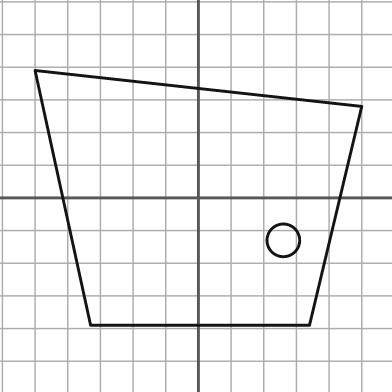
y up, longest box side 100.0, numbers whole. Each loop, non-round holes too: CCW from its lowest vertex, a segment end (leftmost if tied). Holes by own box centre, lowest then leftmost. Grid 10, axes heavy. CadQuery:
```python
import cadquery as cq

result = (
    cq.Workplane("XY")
    .moveTo(-33.0, -39.0)
    .lineTo(34.0, -39.0)
    .lineTo(50.0, 28.0)
    .lineTo(-50.0, 39.0)
    .close()
    .moveTo(26.0, -13.0)
    .circle(5.0)
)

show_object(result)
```